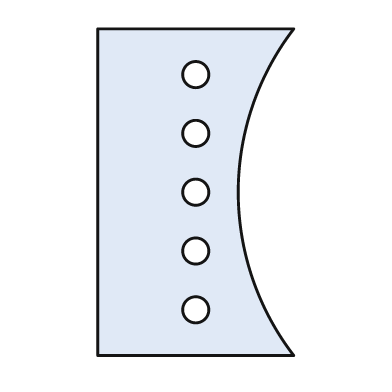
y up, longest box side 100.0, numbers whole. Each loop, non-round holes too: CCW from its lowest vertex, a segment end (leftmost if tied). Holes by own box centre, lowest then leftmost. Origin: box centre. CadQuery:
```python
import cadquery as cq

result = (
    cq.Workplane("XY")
    .moveTo(-30.0, -50.0)
    .lineTo(30.0, -50.0)
    .threePointArc((13.0, 0.0), (30.0, 50.0))
    .lineTo(-30.0, 50.0)
    .close()
    .moveTo(0.0, -36.0)
    .circle(4.0)
    .moveTo(0.0, -18.0)
    .circle(4.0)
    .moveTo(0.0, 0.0)
    .circle(4.0)
    .moveTo(0.0, 18.0)
    .circle(4.0)
    .moveTo(0.0, 36.0)
    .circle(4.0)
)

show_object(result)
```